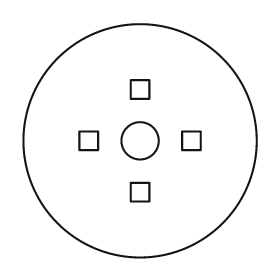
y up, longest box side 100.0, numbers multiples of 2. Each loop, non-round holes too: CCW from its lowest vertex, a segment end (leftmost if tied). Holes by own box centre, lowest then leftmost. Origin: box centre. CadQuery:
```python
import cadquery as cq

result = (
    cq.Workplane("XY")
    .moveTo(0.0, 0.0)
    .circle(50.0)
    .moveTo(-4.0, -26.0)
    .lineTo(4.0, -26.0)
    .lineTo(4.0, -18.0)
    .lineTo(-4.0, -18.0)
    .close()
    .moveTo(-26.0, -4.0)
    .lineTo(-18.0, -4.0)
    .lineTo(-18.0, 4.0)
    .lineTo(-26.0, 4.0)
    .close()
    .moveTo(0.0, 0.0)
    .circle(8.0)
    .moveTo(18.0, -4.0)
    .lineTo(26.0, -4.0)
    .lineTo(26.0, 4.0)
    .lineTo(18.0, 4.0)
    .close()
    .moveTo(-4.0, 18.0)
    .lineTo(4.0, 18.0)
    .lineTo(4.0, 26.0)
    .lineTo(-4.0, 26.0)
    .close()
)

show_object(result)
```